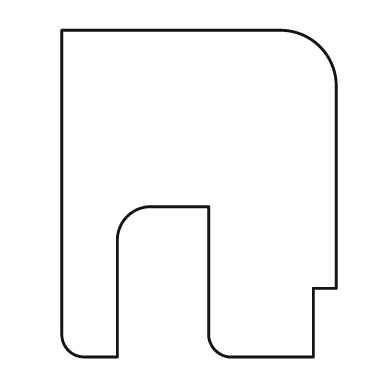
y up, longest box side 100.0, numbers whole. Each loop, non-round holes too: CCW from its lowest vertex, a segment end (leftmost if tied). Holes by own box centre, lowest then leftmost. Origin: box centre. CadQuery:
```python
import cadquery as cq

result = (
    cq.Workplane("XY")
    .moveTo(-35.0, -50.0)
    .lineTo(-25.0, -50.0)
    .lineTo(-25.0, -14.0)
    .threePointArc((-22.0, -7.0), (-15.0, -4.0))
    .lineTo(3.0, -4.0)
    .lineTo(3.0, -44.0)
    .threePointArc((5.0, -48.0), (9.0, -50.0))
    .lineTo(35.0, -50.0)
    .lineTo(35.0, -29.0)
    .lineTo(42.0, -29.0)
    .lineTo(42.0, 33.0)
    .threePointArc((37.0, 45.0), (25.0, 50.0))
    .lineTo(-42.0, 50.0)
    .lineTo(-42.0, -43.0)
    .threePointArc((-40.0, -48.0), (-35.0, -50.0))
    .close()
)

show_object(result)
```